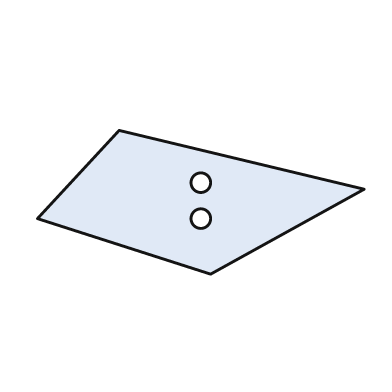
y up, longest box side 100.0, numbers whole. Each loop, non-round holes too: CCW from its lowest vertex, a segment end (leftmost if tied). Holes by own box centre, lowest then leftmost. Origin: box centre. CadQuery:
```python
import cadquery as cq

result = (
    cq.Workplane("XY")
    .moveTo(3.0, -22.0)
    .lineTo(50.0, 4.0)
    .lineTo(-25.0, 22.0)
    .lineTo(-50.0, -5.0)
    .close()
    .moveTo(0.0, -5.0)
    .circle(3.0)
    .moveTo(0.0, 6.0)
    .circle(3.0)
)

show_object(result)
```